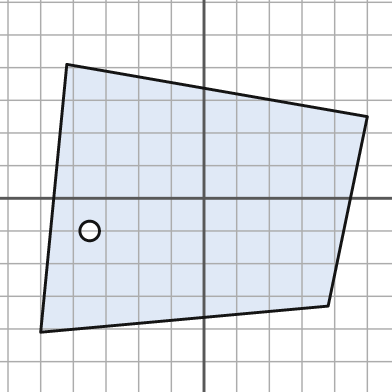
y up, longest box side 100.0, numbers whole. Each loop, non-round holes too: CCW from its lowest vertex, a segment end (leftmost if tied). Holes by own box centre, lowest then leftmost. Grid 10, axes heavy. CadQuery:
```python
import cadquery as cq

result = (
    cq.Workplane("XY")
    .moveTo(-50.0, -41.0)
    .lineTo(38.0, -33.0)
    .lineTo(50.0, 25.0)
    .lineTo(-42.0, 41.0)
    .close()
    .moveTo(-35.0, -10.0)
    .circle(3.0)
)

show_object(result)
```